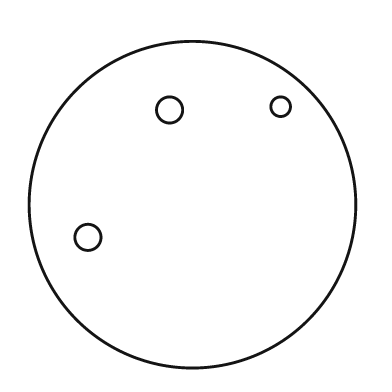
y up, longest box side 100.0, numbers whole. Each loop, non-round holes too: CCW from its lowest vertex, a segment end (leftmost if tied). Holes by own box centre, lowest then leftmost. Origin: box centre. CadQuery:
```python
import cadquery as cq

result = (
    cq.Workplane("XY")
    .moveTo(0.0, 0.0)
    .circle(50.0)
    .moveTo(-32.0, -10.0)
    .circle(4.0)
    .moveTo(-7.0, 29.0)
    .circle(4.0)
    .moveTo(27.0, 30.0)
    .circle(3.0)
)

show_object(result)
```